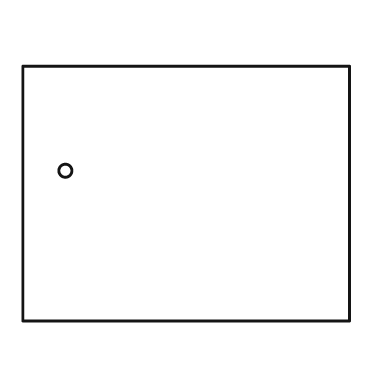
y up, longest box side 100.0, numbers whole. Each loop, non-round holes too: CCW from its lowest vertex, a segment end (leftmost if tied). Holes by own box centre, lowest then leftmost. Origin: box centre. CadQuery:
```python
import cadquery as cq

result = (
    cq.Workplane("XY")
    .moveTo(-50.0, -39.0)
    .lineTo(50.0, -39.0)
    .lineTo(50.0, 39.0)
    .lineTo(-50.0, 39.0)
    .close()
    .moveTo(-37.0, 7.0)
    .circle(2.0)
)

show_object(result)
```